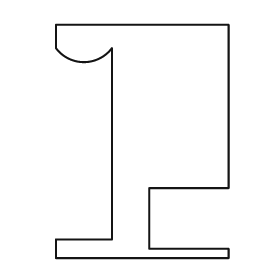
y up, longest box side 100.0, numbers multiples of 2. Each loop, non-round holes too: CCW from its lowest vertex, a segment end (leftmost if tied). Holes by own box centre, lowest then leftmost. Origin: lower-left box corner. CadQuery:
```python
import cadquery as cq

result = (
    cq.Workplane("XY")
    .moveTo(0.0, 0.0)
    .lineTo(74.0, 0.0)
    .lineTo(74.0, 4.0)
    .lineTo(40.0, 4.0)
    .lineTo(40.0, 30.0)
    .lineTo(74.0, 30.0)
    .lineTo(74.0, 100.0)
    .lineTo(0.0, 100.0)
    .lineTo(0.0, 90.0)
    .threePointArc((12.0, 84.0), (24.0, 90.0))
    .lineTo(24.0, 8.0)
    .lineTo(0.0, 8.0)
    .close()
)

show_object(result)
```